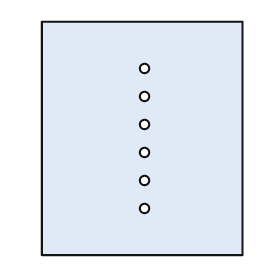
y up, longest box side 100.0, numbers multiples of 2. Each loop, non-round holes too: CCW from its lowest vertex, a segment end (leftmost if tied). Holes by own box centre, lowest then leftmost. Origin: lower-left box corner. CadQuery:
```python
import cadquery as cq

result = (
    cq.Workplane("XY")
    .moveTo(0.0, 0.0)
    .lineTo(86.0, 0.0)
    .lineTo(86.0, 100.0)
    .lineTo(0.0, 100.0)
    .close()
    .moveTo(44.0, 20.0)
    .circle(2.0)
    .moveTo(44.0, 32.0)
    .circle(2.0)
    .moveTo(44.0, 44.0)
    .circle(2.0)
    .moveTo(44.0, 56.0)
    .circle(2.0)
    .moveTo(44.0, 68.0)
    .circle(2.0)
    .moveTo(44.0, 80.0)
    .circle(2.0)
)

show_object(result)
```